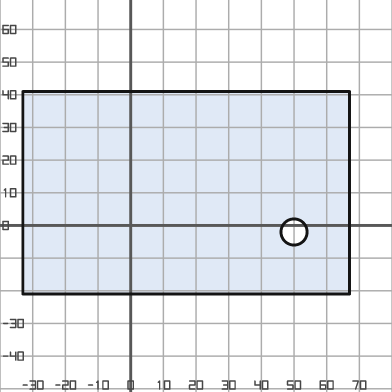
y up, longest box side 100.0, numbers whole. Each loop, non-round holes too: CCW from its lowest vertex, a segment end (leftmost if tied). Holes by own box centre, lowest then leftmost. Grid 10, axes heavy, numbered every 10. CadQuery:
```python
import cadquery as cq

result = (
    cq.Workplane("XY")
    .moveTo(-33.0, -21.0)
    .lineTo(67.0, -21.0)
    .lineTo(67.0, 41.0)
    .lineTo(-33.0, 41.0)
    .close()
    .moveTo(50.0, -2.0)
    .circle(4.0)
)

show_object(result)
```